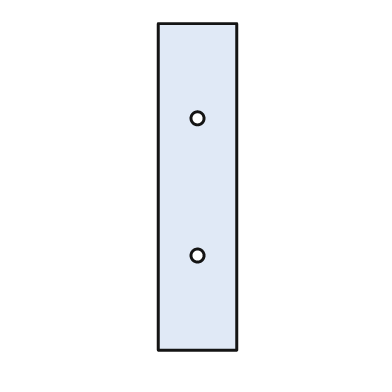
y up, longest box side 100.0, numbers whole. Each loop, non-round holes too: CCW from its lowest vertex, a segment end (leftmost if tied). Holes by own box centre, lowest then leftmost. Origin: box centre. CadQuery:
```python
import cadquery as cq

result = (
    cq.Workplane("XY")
    .moveTo(-12.0, -50.0)
    .lineTo(12.0, -50.0)
    .lineTo(12.0, 50.0)
    .lineTo(-12.0, 50.0)
    .close()
    .moveTo(0.0, -21.0)
    .circle(2.0)
    .moveTo(0.0, 21.0)
    .circle(2.0)
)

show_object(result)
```